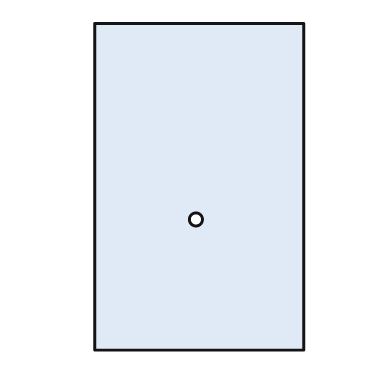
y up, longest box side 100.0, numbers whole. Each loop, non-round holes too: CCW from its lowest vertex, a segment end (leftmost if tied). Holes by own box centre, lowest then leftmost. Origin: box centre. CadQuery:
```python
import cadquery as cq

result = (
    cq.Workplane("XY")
    .moveTo(-32.0, -50.0)
    .lineTo(32.0, -50.0)
    .lineTo(32.0, 50.0)
    .lineTo(-32.0, 50.0)
    .close()
    .moveTo(-1.0, -10.0)
    .circle(2.0)
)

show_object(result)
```